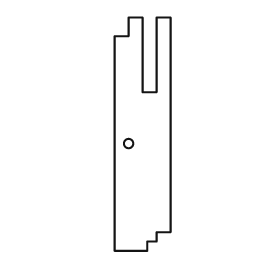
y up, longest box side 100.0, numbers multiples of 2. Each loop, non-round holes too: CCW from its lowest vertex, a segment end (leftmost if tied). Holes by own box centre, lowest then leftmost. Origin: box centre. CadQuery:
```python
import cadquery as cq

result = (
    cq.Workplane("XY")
    .moveTo(-12.0, -50.0)
    .lineTo(2.0, -50.0)
    .lineTo(2.0, -46.0)
    .lineTo(6.0, -46.0)
    .lineTo(6.0, -42.0)
    .lineTo(12.0, -42.0)
    .lineTo(12.0, 50.0)
    .lineTo(6.0, 50.0)
    .lineTo(6.0, 18.0)
    .lineTo(0.0, 18.0)
    .lineTo(0.0, 50.0)
    .lineTo(-6.0, 50.0)
    .lineTo(-6.0, 42.0)
    .lineTo(-12.0, 42.0)
    .close()
    .moveTo(-6.0, -4.0)
    .circle(2.0)
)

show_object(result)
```